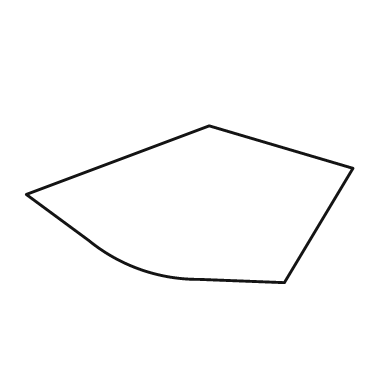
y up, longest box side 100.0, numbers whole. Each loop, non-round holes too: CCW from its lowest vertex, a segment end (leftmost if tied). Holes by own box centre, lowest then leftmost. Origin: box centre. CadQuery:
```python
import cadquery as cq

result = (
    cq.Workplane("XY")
    .moveTo(29.0, -24.0)
    .lineTo(50.0, 11.0)
    .lineTo(6.0, 24.0)
    .lineTo(-50.0, 3.0)
    .lineTo(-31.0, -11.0)
    .threePointArc((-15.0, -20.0), (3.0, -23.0))
    .close()
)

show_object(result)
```